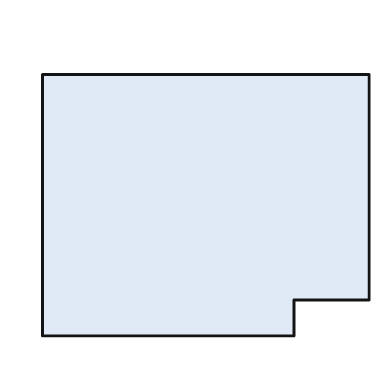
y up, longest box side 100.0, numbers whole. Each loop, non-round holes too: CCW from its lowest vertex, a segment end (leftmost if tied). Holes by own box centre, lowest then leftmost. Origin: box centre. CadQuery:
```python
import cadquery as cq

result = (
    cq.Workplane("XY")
    .moveTo(-50.0, -40.0)
    .lineTo(27.0, -40.0)
    .lineTo(27.0, -29.0)
    .lineTo(50.0, -29.0)
    .lineTo(50.0, 40.0)
    .lineTo(-50.0, 40.0)
    .close()
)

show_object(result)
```